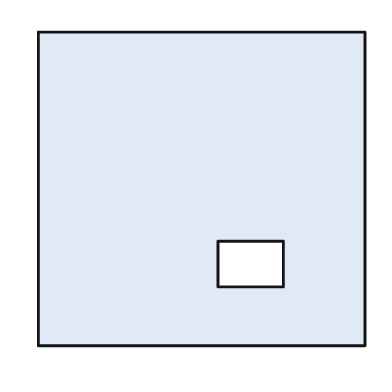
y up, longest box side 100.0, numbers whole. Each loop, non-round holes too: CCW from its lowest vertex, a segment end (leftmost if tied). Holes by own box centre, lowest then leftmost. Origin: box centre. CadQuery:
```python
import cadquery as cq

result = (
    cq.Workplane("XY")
    .moveTo(-50.0, -48.0)
    .lineTo(50.0, -48.0)
    .lineTo(50.0, 48.0)
    .lineTo(-50.0, 48.0)
    .close()
    .moveTo(5.0, -30.0)
    .lineTo(25.0, -30.0)
    .lineTo(25.0, -16.0)
    .lineTo(5.0, -16.0)
    .close()
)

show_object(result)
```